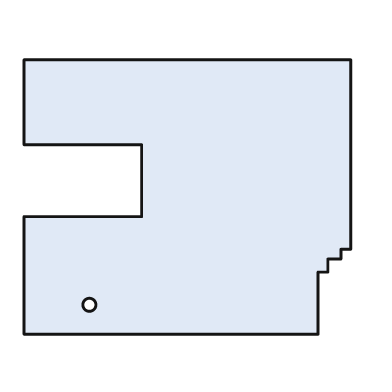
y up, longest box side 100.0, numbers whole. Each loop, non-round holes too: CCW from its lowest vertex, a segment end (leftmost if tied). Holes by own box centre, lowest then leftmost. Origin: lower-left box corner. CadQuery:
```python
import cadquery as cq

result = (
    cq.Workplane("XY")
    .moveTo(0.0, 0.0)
    .lineTo(90.0, 0.0)
    .lineTo(90.0, 19.0)
    .lineTo(93.0, 19.0)
    .lineTo(93.0, 23.0)
    .lineTo(97.0, 23.0)
    .lineTo(97.0, 26.0)
    .lineTo(100.0, 26.0)
    .lineTo(100.0, 84.0)
    .lineTo(0.0, 84.0)
    .lineTo(0.0, 58.0)
    .lineTo(36.0, 58.0)
    .lineTo(36.0, 36.0)
    .lineTo(0.0, 36.0)
    .close()
    .moveTo(20.0, 9.0)
    .circle(2.0)
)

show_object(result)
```